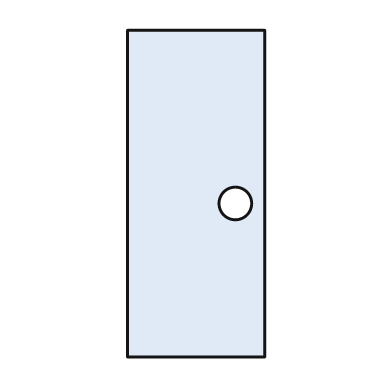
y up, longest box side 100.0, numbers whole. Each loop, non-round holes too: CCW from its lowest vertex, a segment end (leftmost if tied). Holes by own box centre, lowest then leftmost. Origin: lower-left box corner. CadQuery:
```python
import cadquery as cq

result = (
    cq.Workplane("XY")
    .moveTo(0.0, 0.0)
    .lineTo(42.0, 0.0)
    .lineTo(42.0, 100.0)
    .lineTo(0.0, 100.0)
    .close()
    .moveTo(33.0, 47.0)
    .circle(5.0)
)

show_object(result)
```